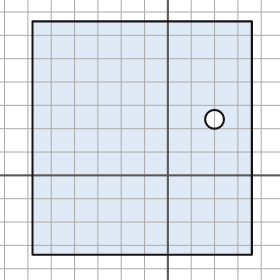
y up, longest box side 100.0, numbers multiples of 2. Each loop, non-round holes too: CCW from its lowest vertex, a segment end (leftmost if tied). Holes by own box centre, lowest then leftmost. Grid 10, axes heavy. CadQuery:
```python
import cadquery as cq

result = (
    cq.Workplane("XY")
    .moveTo(-58.0, -34.0)
    .lineTo(36.0, -34.0)
    .lineTo(36.0, 66.0)
    .lineTo(-58.0, 66.0)
    .close()
    .moveTo(20.0, 24.0)
    .circle(4.0)
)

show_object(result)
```